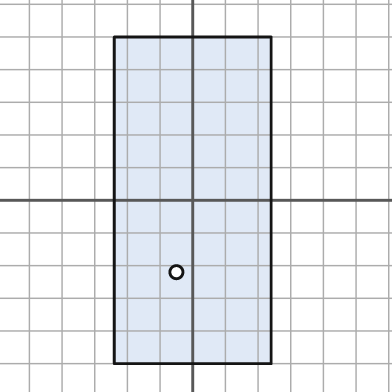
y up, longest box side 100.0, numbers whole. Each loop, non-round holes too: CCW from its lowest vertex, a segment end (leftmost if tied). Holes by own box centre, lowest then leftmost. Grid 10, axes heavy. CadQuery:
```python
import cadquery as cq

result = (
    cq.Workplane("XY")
    .moveTo(-24.0, -50.0)
    .lineTo(24.0, -50.0)
    .lineTo(24.0, 50.0)
    .lineTo(-24.0, 50.0)
    .close()
    .moveTo(-5.0, -22.0)
    .circle(2.0)
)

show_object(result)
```